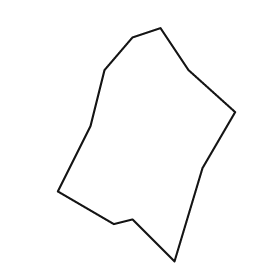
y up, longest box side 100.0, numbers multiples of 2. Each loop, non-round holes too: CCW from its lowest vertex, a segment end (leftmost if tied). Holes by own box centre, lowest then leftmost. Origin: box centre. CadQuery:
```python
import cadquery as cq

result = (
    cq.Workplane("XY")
    .moveTo(12.0, -50.0)
    .lineTo(24.0, -10.0)
    .lineTo(38.0, 14.0)
    .lineTo(18.0, 32.0)
    .lineTo(6.0, 50.0)
    .lineTo(-6.0, 46.0)
    .lineTo(-18.0, 32.0)
    .lineTo(-24.0, 8.0)
    .lineTo(-38.0, -20.0)
    .lineTo(-14.0, -34.0)
    .lineTo(-6.0, -32.0)
    .close()
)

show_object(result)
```